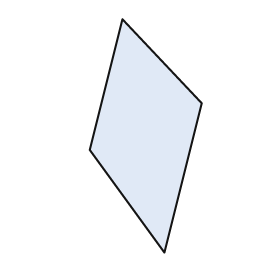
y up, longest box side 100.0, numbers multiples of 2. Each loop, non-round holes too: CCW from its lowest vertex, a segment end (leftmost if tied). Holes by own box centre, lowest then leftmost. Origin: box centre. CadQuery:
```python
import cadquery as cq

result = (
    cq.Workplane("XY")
    .moveTo(8.0, -50.0)
    .lineTo(24.0, 14.0)
    .lineTo(-10.0, 50.0)
    .lineTo(-24.0, -6.0)
    .close()
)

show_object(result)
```